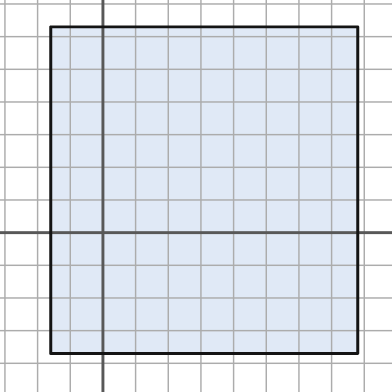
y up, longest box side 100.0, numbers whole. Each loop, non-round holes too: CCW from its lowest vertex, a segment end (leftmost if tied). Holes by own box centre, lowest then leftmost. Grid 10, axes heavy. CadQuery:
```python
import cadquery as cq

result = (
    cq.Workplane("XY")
    .moveTo(-16.0, -37.0)
    .lineTo(78.0, -37.0)
    .lineTo(78.0, 63.0)
    .lineTo(-16.0, 63.0)
    .close()
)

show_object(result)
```